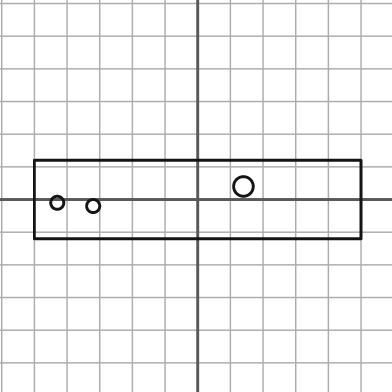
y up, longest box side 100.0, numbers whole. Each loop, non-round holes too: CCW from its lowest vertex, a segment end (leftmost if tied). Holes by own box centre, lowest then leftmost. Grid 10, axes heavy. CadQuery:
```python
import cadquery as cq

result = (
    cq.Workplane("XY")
    .moveTo(-50.0, -12.0)
    .lineTo(50.0, -12.0)
    .lineTo(50.0, 12.0)
    .lineTo(-50.0, 12.0)
    .close()
    .moveTo(-32.0, -2.0)
    .circle(2.0)
    .moveTo(-43.0, -1.0)
    .circle(2.0)
    .moveTo(14.0, 4.0)
    .circle(3.0)
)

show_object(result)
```